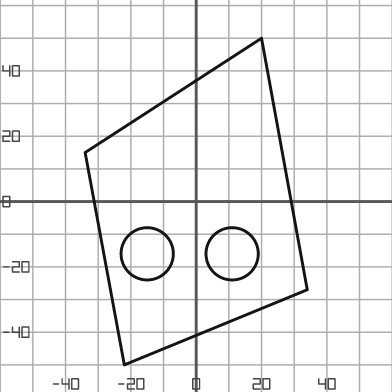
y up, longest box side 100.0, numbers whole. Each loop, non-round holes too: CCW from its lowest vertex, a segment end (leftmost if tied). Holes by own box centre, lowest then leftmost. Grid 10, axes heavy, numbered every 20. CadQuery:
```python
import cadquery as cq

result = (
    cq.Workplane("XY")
    .moveTo(-22.0, -50.0)
    .lineTo(34.0, -27.0)
    .lineTo(20.0, 50.0)
    .lineTo(-34.0, 15.0)
    .close()
    .moveTo(-15.0, -16.0)
    .circle(8.0)
    .moveTo(11.0, -16.0)
    .circle(8.0)
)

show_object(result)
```